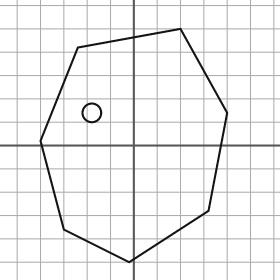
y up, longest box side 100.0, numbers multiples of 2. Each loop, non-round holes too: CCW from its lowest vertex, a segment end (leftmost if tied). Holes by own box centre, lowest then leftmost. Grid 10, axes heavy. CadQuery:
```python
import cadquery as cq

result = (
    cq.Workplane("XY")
    .moveTo(-2.0, -50.0)
    .lineTo(32.0, -28.0)
    .lineTo(40.0, 14.0)
    .lineTo(20.0, 50.0)
    .lineTo(-24.0, 42.0)
    .lineTo(-40.0, 2.0)
    .lineTo(-30.0, -36.0)
    .close()
    .moveTo(-18.0, 14.0)
    .circle(4.0)
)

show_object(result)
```